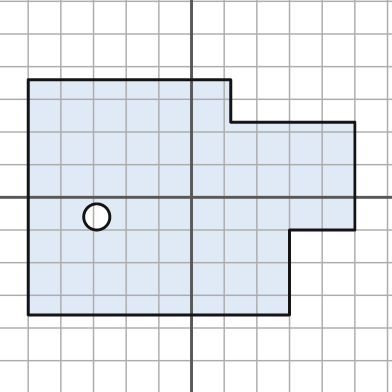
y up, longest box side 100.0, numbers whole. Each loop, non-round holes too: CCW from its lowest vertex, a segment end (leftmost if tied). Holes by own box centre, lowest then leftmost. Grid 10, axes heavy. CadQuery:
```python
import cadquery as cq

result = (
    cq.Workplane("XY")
    .moveTo(-50.0, -36.0)
    .lineTo(30.0, -36.0)
    .lineTo(30.0, -10.0)
    .lineTo(50.0, -10.0)
    .lineTo(50.0, 23.0)
    .lineTo(12.0, 23.0)
    .lineTo(12.0, 36.0)
    .lineTo(-50.0, 36.0)
    .close()
    .moveTo(-29.0, -6.0)
    .circle(4.0)
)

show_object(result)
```